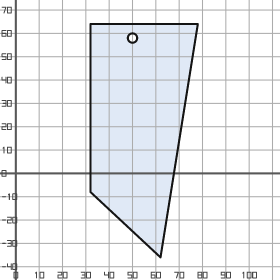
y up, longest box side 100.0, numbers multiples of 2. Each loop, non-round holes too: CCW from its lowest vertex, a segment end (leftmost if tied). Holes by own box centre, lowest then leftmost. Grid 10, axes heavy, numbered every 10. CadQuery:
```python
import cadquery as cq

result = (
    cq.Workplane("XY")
    .moveTo(62.0, -36.0)
    .lineTo(78.0, 64.0)
    .lineTo(32.0, 64.0)
    .lineTo(32.0, -8.0)
    .close()
    .moveTo(50.0, 58.0)
    .circle(2.0)
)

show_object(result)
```